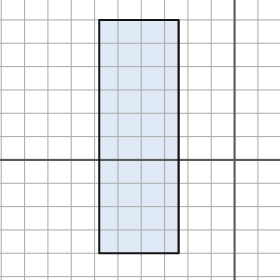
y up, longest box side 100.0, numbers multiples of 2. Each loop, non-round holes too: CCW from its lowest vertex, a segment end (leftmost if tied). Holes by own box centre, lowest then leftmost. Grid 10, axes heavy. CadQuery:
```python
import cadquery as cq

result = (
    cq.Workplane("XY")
    .moveTo(-58.0, -40.0)
    .lineTo(-24.0, -40.0)
    .lineTo(-24.0, 60.0)
    .lineTo(-58.0, 60.0)
    .close()
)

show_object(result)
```